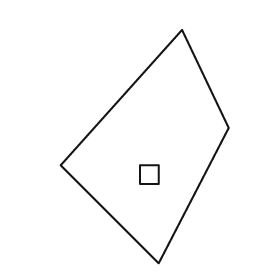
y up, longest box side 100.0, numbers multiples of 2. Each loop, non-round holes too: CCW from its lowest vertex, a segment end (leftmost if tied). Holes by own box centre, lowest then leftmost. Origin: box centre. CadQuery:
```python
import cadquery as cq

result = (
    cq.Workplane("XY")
    .moveTo(6.0, -50.0)
    .lineTo(36.0, 8.0)
    .lineTo(16.0, 50.0)
    .lineTo(-36.0, -8.0)
    .close()
    .moveTo(-2.0, -16.0)
    .lineTo(6.0, -16.0)
    .lineTo(6.0, -8.0)
    .lineTo(-2.0, -8.0)
    .close()
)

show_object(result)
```